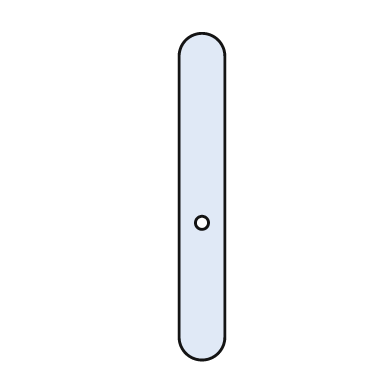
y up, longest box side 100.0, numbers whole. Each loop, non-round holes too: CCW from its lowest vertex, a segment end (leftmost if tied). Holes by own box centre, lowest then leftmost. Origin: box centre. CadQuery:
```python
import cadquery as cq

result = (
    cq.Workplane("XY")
    .moveTo(-7.0, -43.0)
    .threePointArc((0.0, -50.0), (7.0, -43.0))
    .lineTo(7.0, 43.0)
    .threePointArc((0.0, 50.0), (-7.0, 43.0))
    .close()
    .moveTo(0.0, -8.0)
    .circle(2.0)
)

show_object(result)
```